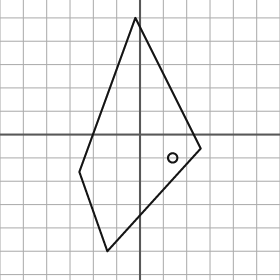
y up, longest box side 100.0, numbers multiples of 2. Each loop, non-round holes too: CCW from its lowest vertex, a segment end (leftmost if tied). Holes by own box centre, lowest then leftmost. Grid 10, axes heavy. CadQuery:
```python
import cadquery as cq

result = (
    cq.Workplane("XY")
    .moveTo(-14.0, -50.0)
    .lineTo(26.0, -6.0)
    .lineTo(-2.0, 50.0)
    .lineTo(-26.0, -16.0)
    .close()
    .moveTo(14.0, -10.0)
    .circle(2.0)
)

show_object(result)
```